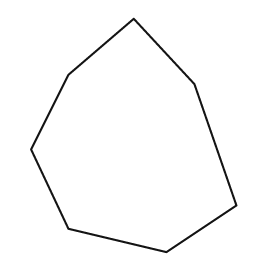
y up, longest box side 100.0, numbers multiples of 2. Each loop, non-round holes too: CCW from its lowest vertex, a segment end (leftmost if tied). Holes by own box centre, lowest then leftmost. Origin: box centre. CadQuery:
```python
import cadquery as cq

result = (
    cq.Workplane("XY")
    .moveTo(14.0, -50.0)
    .lineTo(44.0, -30.0)
    .lineTo(26.0, 22.0)
    .lineTo(0.0, 50.0)
    .lineTo(-28.0, 26.0)
    .lineTo(-44.0, -6.0)
    .lineTo(-28.0, -40.0)
    .close()
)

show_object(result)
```